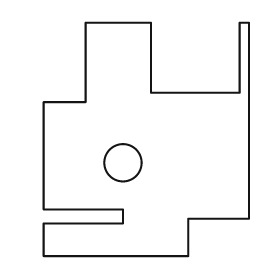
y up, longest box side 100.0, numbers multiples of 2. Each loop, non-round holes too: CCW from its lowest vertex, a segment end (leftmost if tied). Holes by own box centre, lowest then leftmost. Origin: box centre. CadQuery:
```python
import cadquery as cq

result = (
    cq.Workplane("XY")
    .moveTo(-44.0, -50.0)
    .lineTo(18.0, -50.0)
    .lineTo(18.0, -34.0)
    .lineTo(44.0, -34.0)
    .lineTo(44.0, 50.0)
    .lineTo(40.0, 50.0)
    .lineTo(40.0, 20.0)
    .lineTo(2.0, 20.0)
    .lineTo(2.0, 50.0)
    .lineTo(-26.0, 50.0)
    .lineTo(-26.0, 16.0)
    .lineTo(-44.0, 16.0)
    .lineTo(-44.0, -30.0)
    .lineTo(-10.0, -30.0)
    .lineTo(-10.0, -36.0)
    .lineTo(-44.0, -36.0)
    .close()
    .moveTo(-10.0, -10.0)
    .circle(8.0)
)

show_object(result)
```